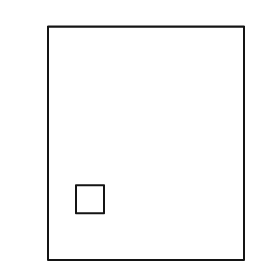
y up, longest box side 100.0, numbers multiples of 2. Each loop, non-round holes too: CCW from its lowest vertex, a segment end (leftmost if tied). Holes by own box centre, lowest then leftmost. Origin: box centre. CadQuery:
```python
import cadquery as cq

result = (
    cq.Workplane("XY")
    .moveTo(-42.0, -50.0)
    .lineTo(42.0, -50.0)
    .lineTo(42.0, 50.0)
    .lineTo(-42.0, 50.0)
    .close()
    .moveTo(-30.0, -30.0)
    .lineTo(-18.0, -30.0)
    .lineTo(-18.0, -18.0)
    .lineTo(-30.0, -18.0)
    .close()
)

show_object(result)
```